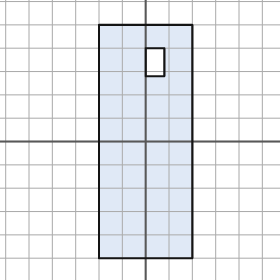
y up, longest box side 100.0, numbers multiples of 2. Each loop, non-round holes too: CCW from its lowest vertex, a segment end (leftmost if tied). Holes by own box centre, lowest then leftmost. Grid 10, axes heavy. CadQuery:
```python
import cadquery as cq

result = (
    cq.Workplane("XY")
    .moveTo(-20.0, -50.0)
    .lineTo(20.0, -50.0)
    .lineTo(20.0, 50.0)
    .lineTo(-20.0, 50.0)
    .close()
    .moveTo(0.0, 28.0)
    .lineTo(8.0, 28.0)
    .lineTo(8.0, 40.0)
    .lineTo(0.0, 40.0)
    .close()
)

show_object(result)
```